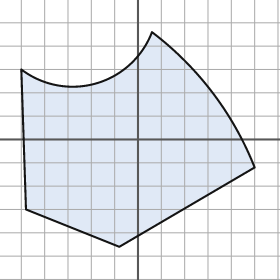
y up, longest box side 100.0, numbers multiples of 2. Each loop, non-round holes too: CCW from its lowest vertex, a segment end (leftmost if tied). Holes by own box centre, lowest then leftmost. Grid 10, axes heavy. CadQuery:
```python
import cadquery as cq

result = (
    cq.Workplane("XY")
    .moveTo(-8.0, -46.0)
    .lineTo(50.0, -12.0)
    .threePointArc((32.0, 20.0), (6.0, 46.0))
    .threePointArc((-18.0, 24.0), (-50.0, 30.0))
    .lineTo(-48.0, -30.0)
    .close()
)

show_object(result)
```